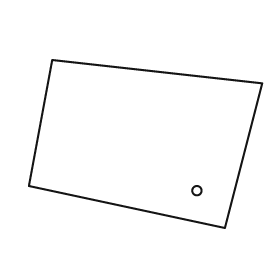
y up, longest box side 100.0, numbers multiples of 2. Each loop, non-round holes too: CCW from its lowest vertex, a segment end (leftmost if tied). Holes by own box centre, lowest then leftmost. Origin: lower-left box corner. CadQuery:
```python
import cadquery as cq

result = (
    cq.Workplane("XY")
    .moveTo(84.0, 0.0)
    .lineTo(100.0, 62.0)
    .lineTo(10.0, 72.0)
    .lineTo(0.0, 18.0)
    .close()
    .moveTo(72.0, 16.0)
    .circle(2.0)
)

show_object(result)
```